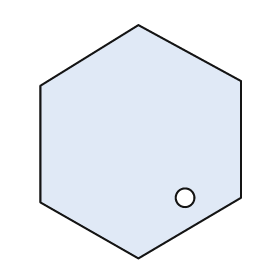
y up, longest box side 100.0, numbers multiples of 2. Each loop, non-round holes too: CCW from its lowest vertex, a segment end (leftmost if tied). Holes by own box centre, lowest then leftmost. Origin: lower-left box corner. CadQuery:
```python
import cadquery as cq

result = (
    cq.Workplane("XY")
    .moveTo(42.0, 0.0)
    .lineTo(86.0, 26.0)
    .lineTo(86.0, 76.0)
    .lineTo(42.0, 100.0)
    .lineTo(0.0, 74.0)
    .lineTo(0.0, 24.0)
    .close()
    .moveTo(62.0, 26.0)
    .circle(4.0)
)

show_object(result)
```